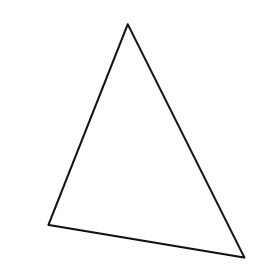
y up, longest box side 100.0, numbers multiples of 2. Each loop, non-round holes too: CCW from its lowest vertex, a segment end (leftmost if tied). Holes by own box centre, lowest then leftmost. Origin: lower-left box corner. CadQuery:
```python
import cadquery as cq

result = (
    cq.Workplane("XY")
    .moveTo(84.0, 0.0)
    .lineTo(34.0, 100.0)
    .lineTo(0.0, 14.0)
    .close()
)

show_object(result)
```